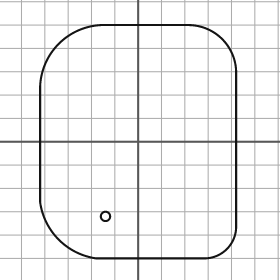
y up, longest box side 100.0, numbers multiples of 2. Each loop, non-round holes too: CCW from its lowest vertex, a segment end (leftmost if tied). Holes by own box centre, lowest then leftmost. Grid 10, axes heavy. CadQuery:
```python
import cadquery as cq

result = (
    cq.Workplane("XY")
    .moveTo(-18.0, -50.0)
    .lineTo(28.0, -50.0)
    .threePointArc((38.0, -46.0), (42.0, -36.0))
    .lineTo(42.0, 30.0)
    .threePointArc((36.0, 44.0), (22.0, 50.0))
    .lineTo(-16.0, 50.0)
    .threePointArc((-34.0, 42.0), (-42.0, 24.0))
    .lineTo(-42.0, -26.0)
    .threePointArc((-34.0, -42.0), (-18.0, -50.0))
    .close()
    .moveTo(-14.0, -32.0)
    .circle(2.0)
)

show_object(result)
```